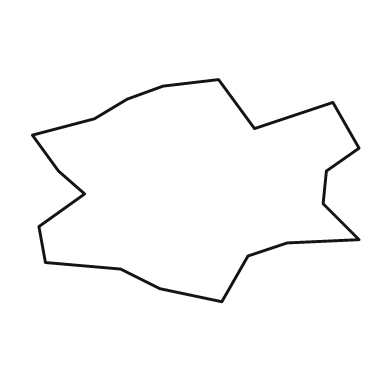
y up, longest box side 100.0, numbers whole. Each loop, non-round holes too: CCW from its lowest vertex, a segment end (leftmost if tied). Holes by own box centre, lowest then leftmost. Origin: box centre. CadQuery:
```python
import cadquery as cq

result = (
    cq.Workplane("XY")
    .moveTo(8.0, -34.0)
    .lineTo(16.0, -20.0)
    .lineTo(28.0, -16.0)
    .lineTo(50.0, -15.0)
    .lineTo(39.0, -4.0)
    .lineTo(40.0, 6.0)
    .lineTo(50.0, 13.0)
    .lineTo(42.0, 27.0)
    .lineTo(18.0, 19.0)
    .lineTo(7.0, 34.0)
    .lineTo(-10.0, 32.0)
    .lineTo(-21.0, 28.0)
    .lineTo(-31.0, 22.0)
    .lineTo(-50.0, 17.0)
    .lineTo(-42.0, 6.0)
    .lineTo(-34.0, -1.0)
    .lineTo(-48.0, -11.0)
    .lineTo(-46.0, -22.0)
    .lineTo(-23.0, -24.0)
    .lineTo(-11.0, -30.0)
    .close()
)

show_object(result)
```